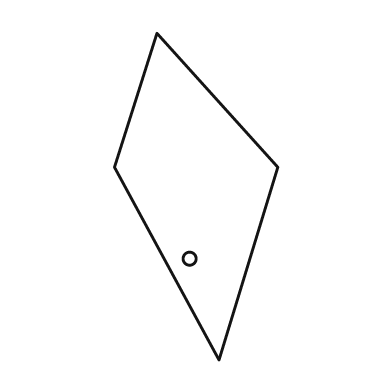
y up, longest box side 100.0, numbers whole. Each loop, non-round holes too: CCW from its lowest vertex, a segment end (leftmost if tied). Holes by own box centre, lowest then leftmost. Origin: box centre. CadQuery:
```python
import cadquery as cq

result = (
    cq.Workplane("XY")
    .moveTo(7.0, -50.0)
    .lineTo(25.0, 9.0)
    .lineTo(-12.0, 50.0)
    .lineTo(-25.0, 9.0)
    .close()
    .moveTo(-2.0, -19.0)
    .circle(2.0)
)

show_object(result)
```